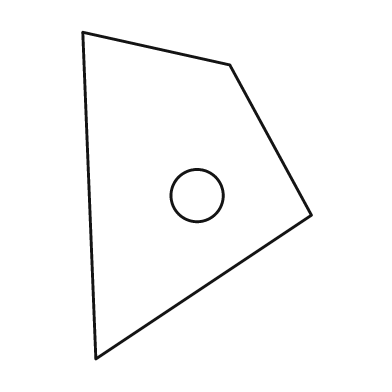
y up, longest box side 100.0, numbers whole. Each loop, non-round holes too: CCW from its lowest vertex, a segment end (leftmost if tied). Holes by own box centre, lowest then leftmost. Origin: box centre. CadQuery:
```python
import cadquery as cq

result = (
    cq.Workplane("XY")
    .moveTo(-31.0, -50.0)
    .lineTo(35.0, -6.0)
    .lineTo(10.0, 40.0)
    .lineTo(-35.0, 50.0)
    .close()
    .moveTo(0.0, 0.0)
    .circle(8.0)
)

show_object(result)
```